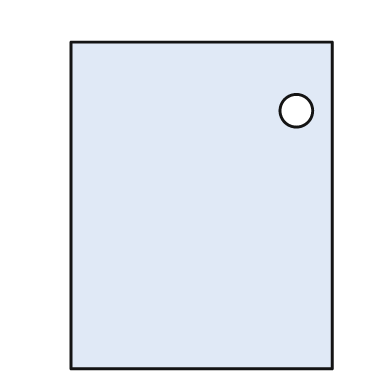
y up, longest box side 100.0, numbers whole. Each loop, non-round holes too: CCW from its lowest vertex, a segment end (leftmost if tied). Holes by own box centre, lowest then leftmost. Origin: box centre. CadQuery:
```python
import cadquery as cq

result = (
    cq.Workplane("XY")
    .moveTo(-40.0, -50.0)
    .lineTo(40.0, -50.0)
    .lineTo(40.0, 50.0)
    .lineTo(-40.0, 50.0)
    .close()
    .moveTo(29.0, 29.0)
    .circle(5.0)
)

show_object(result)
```